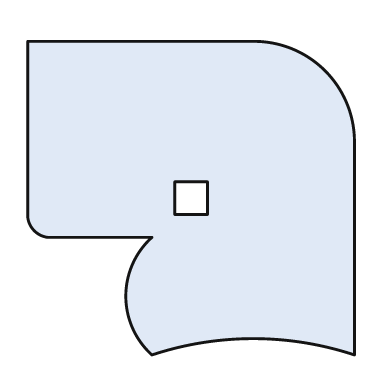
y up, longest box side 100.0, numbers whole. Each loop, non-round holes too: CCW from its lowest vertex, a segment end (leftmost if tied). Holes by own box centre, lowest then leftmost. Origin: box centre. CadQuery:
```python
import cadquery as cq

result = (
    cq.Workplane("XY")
    .moveTo(-12.0, -48.0)
    .threePointArc((19.0, -43.0), (50.0, -48.0))
    .lineTo(50.0, 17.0)
    .threePointArc((41.0, 39.0), (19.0, 48.0))
    .lineTo(-50.0, 48.0)
    .lineTo(-50.0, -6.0)
    .threePointArc((-48.0, -10.0), (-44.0, -12.0))
    .lineTo(-12.0, -12.0)
    .threePointArc((-20.0, -30.0), (-12.0, -48.0))
    .close()
    .moveTo(-5.0, -5.0)
    .lineTo(5.0, -5.0)
    .lineTo(5.0, 5.0)
    .lineTo(-5.0, 5.0)
    .close()
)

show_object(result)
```